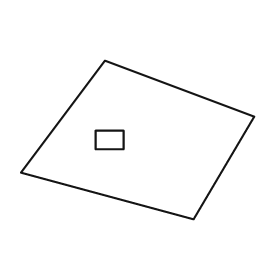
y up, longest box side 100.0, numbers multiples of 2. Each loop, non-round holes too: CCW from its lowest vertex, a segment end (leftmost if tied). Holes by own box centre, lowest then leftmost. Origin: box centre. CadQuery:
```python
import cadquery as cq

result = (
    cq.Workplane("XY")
    .moveTo(24.0, -34.0)
    .lineTo(50.0, 10.0)
    .lineTo(-14.0, 34.0)
    .lineTo(-50.0, -14.0)
    .close()
    .moveTo(-18.0, -4.0)
    .lineTo(-6.0, -4.0)
    .lineTo(-6.0, 4.0)
    .lineTo(-18.0, 4.0)
    .close()
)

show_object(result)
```